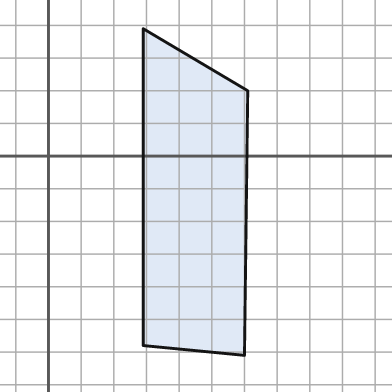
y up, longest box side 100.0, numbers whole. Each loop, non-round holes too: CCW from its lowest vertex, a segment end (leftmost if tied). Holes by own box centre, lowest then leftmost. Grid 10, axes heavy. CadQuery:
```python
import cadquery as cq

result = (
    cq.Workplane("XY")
    .moveTo(60.0, -61.0)
    .lineTo(61.0, 20.0)
    .lineTo(29.0, 39.0)
    .lineTo(29.0, -58.0)
    .close()
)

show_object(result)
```